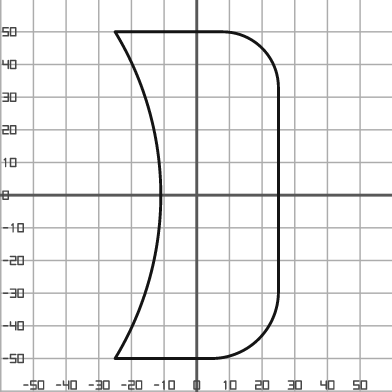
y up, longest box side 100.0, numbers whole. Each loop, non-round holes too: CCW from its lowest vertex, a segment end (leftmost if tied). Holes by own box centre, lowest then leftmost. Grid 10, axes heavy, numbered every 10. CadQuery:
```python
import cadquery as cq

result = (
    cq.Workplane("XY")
    .moveTo(-25.0, -50.0)
    .lineTo(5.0, -50.0)
    .threePointArc((19.0, -44.0), (25.0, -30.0))
    .lineTo(25.0, 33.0)
    .threePointArc((20.0, 45.0), (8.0, 50.0))
    .lineTo(-25.0, 50.0)
    .threePointArc((-11.0, 0.0), (-25.0, -50.0))
    .close()
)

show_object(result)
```